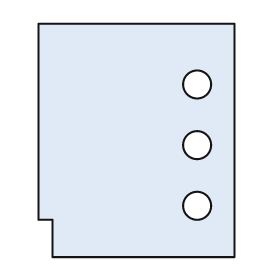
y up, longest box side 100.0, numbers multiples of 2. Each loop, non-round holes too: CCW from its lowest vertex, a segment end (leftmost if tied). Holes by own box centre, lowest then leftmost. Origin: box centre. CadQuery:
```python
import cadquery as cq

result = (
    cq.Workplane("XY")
    .moveTo(-36.0, -50.0)
    .lineTo(42.0, -50.0)
    .lineTo(42.0, 50.0)
    .lineTo(-42.0, 50.0)
    .lineTo(-42.0, -34.0)
    .lineTo(-36.0, -34.0)
    .close()
    .moveTo(26.0, -28.0)
    .circle(6.0)
    .moveTo(26.0, -2.0)
    .circle(6.0)
    .moveTo(26.0, 24.0)
    .circle(6.0)
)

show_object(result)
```